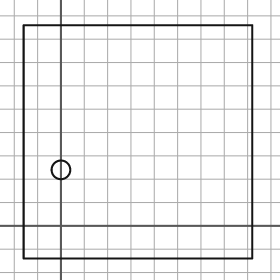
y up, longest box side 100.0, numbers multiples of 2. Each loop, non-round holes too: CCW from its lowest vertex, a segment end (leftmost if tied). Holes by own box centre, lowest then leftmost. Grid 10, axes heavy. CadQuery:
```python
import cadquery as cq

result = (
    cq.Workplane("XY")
    .moveTo(-16.0, -14.0)
    .lineTo(82.0, -14.0)
    .lineTo(82.0, 86.0)
    .lineTo(-16.0, 86.0)
    .close()
    .moveTo(0.0, 24.0)
    .circle(4.0)
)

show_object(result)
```